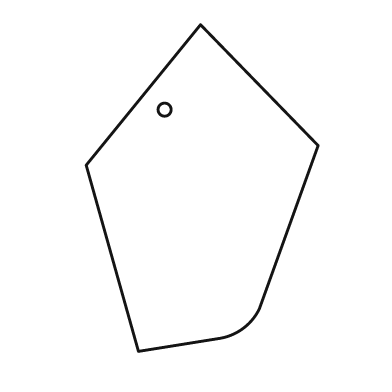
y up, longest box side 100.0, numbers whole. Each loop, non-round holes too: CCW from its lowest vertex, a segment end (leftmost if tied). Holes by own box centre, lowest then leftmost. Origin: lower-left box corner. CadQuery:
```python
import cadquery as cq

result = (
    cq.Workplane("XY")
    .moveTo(16.0, 0.0)
    .lineTo(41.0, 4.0)
    .threePointArc((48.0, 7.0), (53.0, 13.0))
    .lineTo(71.0, 63.0)
    .lineTo(35.0, 100.0)
    .lineTo(0.0, 57.0)
    .close()
    .moveTo(24.0, 74.0)
    .circle(2.0)
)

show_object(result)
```